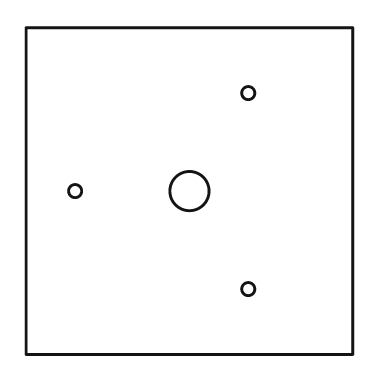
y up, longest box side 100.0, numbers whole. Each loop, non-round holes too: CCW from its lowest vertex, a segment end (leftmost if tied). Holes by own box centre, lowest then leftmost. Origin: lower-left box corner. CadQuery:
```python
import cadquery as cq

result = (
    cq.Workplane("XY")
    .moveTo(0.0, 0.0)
    .lineTo(100.0, 0.0)
    .lineTo(100.0, 100.0)
    .lineTo(0.0, 100.0)
    .close()
    .moveTo(68.0, 20.0)
    .circle(2.0)
    .moveTo(15.0, 50.0)
    .circle(2.0)
    .moveTo(50.0, 50.0)
    .circle(6.0)
    .moveTo(68.0, 80.0)
    .circle(2.0)
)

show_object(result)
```